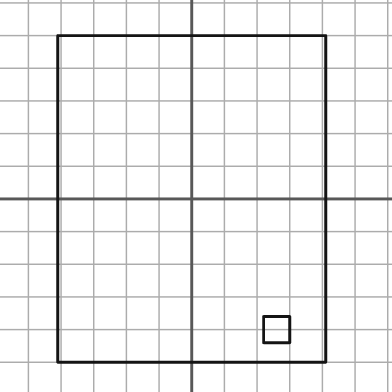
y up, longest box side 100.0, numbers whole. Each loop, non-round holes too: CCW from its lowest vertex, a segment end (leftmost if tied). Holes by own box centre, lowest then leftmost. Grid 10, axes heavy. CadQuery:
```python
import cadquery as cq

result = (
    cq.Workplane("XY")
    .moveTo(-41.0, -50.0)
    .lineTo(41.0, -50.0)
    .lineTo(41.0, 50.0)
    .lineTo(-41.0, 50.0)
    .close()
    .moveTo(22.0, -44.0)
    .lineTo(30.0, -44.0)
    .lineTo(30.0, -36.0)
    .lineTo(22.0, -36.0)
    .close()
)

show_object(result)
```